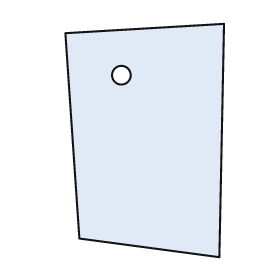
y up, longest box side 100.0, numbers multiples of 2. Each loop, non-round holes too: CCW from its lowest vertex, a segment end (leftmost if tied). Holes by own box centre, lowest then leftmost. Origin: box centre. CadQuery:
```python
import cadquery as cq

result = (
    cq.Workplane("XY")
    .moveTo(32.0, -50.0)
    .lineTo(34.0, 50.0)
    .lineTo(-34.0, 46.0)
    .lineTo(-28.0, -42.0)
    .close()
    .moveTo(-10.0, 28.0)
    .circle(4.0)
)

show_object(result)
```